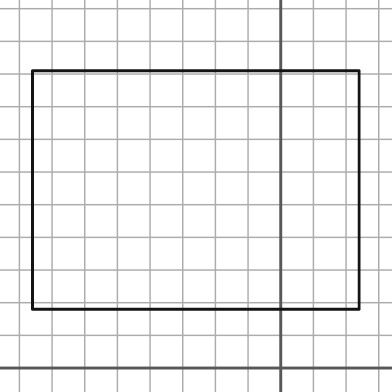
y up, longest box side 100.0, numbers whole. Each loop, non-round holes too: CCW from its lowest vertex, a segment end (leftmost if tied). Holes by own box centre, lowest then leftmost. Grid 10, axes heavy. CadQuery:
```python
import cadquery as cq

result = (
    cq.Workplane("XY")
    .moveTo(-76.0, 18.0)
    .lineTo(24.0, 18.0)
    .lineTo(24.0, 91.0)
    .lineTo(-76.0, 91.0)
    .close()
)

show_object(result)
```